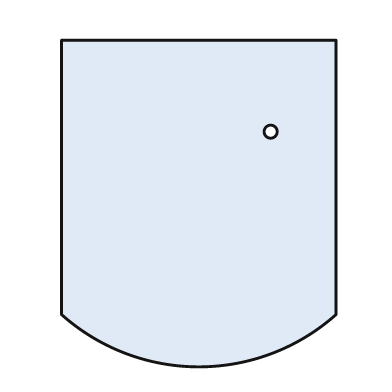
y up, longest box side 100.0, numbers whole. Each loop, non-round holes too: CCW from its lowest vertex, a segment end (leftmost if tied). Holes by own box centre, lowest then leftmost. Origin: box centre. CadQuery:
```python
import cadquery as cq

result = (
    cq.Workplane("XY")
    .moveTo(-42.0, -34.0)
    .threePointArc((0.0, -50.0), (42.0, -34.0))
    .lineTo(42.0, 50.0)
    .lineTo(-42.0, 50.0)
    .close()
    .moveTo(22.0, 22.0)
    .circle(2.0)
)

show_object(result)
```